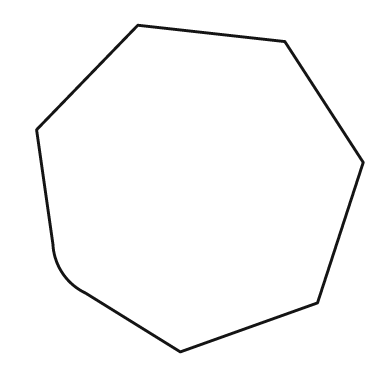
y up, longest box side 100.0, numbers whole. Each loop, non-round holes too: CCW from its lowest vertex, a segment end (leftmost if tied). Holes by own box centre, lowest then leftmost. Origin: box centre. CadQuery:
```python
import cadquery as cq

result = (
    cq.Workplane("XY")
    .moveTo(-6.0, -50.0)
    .lineTo(36.0, -35.0)
    .lineTo(50.0, 8.0)
    .lineTo(26.0, 45.0)
    .lineTo(-19.0, 50.0)
    .lineTo(-50.0, 18.0)
    .lineTo(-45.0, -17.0)
    .threePointArc((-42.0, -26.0), (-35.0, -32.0))
    .close()
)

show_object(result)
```